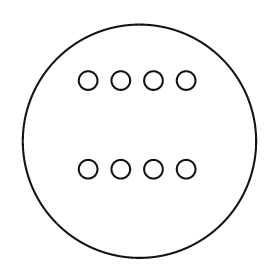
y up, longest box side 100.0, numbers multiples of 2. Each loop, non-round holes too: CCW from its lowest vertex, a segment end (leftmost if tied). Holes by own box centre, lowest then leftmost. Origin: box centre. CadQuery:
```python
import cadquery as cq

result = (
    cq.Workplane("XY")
    .moveTo(0.0, 0.0)
    .circle(50.0)
    .moveTo(-22.0, -12.0)
    .circle(4.0)
    .moveTo(-8.0, -12.0)
    .circle(4.0)
    .moveTo(6.0, -12.0)
    .circle(4.0)
    .moveTo(20.0, -12.0)
    .circle(4.0)
    .moveTo(-22.0, 26.0)
    .circle(4.0)
    .moveTo(-8.0, 26.0)
    .circle(4.0)
    .moveTo(6.0, 26.0)
    .circle(4.0)
    .moveTo(20.0, 26.0)
    .circle(4.0)
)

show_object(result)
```